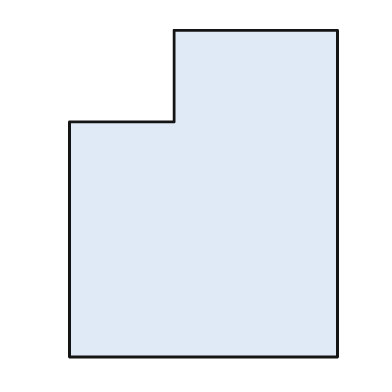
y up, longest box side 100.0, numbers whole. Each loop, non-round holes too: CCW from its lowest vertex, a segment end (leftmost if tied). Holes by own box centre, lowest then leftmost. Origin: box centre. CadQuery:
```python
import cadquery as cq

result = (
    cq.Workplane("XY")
    .moveTo(-41.0, -50.0)
    .lineTo(41.0, -50.0)
    .lineTo(41.0, 50.0)
    .lineTo(-9.0, 50.0)
    .lineTo(-9.0, 22.0)
    .lineTo(-41.0, 22.0)
    .close()
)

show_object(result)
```